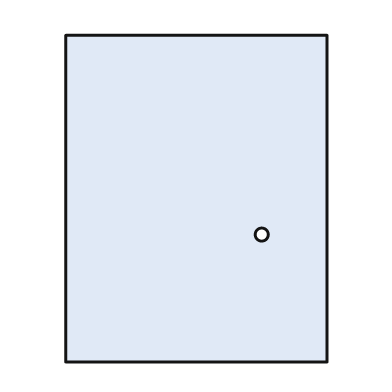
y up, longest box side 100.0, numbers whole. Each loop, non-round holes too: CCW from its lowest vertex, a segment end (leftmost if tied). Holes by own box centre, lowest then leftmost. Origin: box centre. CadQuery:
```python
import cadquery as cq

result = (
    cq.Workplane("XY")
    .moveTo(-40.0, -50.0)
    .lineTo(40.0, -50.0)
    .lineTo(40.0, 50.0)
    .lineTo(-40.0, 50.0)
    .close()
    .moveTo(20.0, -11.0)
    .circle(2.0)
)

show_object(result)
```